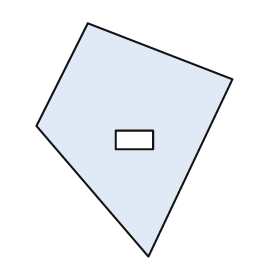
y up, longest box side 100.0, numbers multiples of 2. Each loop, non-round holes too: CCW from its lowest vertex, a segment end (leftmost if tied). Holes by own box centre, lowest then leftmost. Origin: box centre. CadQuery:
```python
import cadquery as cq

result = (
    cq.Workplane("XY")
    .moveTo(6.0, -50.0)
    .lineTo(42.0, 26.0)
    .lineTo(-20.0, 50.0)
    .lineTo(-42.0, 6.0)
    .close()
    .moveTo(-8.0, -4.0)
    .lineTo(8.0, -4.0)
    .lineTo(8.0, 4.0)
    .lineTo(-8.0, 4.0)
    .close()
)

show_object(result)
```